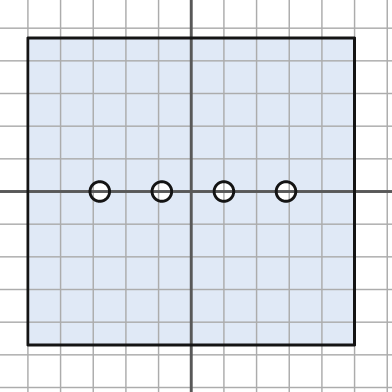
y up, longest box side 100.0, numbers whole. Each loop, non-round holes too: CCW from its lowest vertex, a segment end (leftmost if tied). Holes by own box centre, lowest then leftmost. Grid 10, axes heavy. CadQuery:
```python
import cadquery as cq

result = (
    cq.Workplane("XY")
    .moveTo(-50.0, -47.0)
    .lineTo(50.0, -47.0)
    .lineTo(50.0, 47.0)
    .lineTo(-50.0, 47.0)
    .close()
    .moveTo(-28.0, 0.0)
    .circle(3.0)
    .moveTo(-9.0, 0.0)
    .circle(3.0)
    .moveTo(10.0, 0.0)
    .circle(3.0)
    .moveTo(29.0, 0.0)
    .circle(3.0)
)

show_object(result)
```